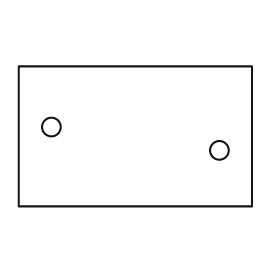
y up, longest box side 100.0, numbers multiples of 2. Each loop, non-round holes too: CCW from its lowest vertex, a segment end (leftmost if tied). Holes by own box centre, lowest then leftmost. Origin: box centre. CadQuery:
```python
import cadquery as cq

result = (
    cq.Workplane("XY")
    .moveTo(-50.0, -30.0)
    .lineTo(50.0, -30.0)
    .lineTo(50.0, 30.0)
    .lineTo(-50.0, 30.0)
    .close()
    .moveTo(36.0, -6.0)
    .circle(4.0)
    .moveTo(-36.0, 4.0)
    .circle(4.0)
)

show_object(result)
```